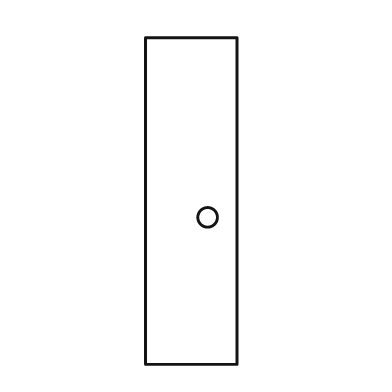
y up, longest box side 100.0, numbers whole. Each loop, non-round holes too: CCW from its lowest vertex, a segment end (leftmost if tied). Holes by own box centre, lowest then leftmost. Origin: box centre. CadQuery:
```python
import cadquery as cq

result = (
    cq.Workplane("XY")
    .moveTo(-14.0, -50.0)
    .lineTo(14.0, -50.0)
    .lineTo(14.0, 50.0)
    .lineTo(-14.0, 50.0)
    .close()
    .moveTo(5.0, -5.0)
    .circle(3.0)
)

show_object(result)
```